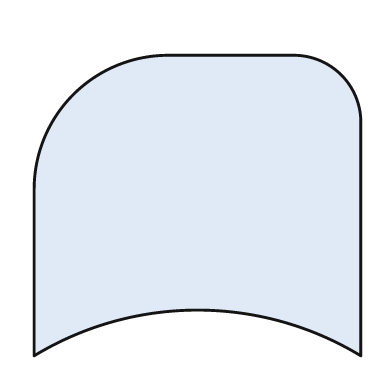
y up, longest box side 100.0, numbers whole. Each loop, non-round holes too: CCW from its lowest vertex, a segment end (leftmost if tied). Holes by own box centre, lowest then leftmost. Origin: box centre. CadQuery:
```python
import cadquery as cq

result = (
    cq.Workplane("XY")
    .moveTo(-50.0, -46.0)
    .threePointArc((0.0, -32.0), (50.0, -46.0))
    .lineTo(50.0, 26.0)
    .threePointArc((44.0, 40.0), (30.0, 46.0))
    .lineTo(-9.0, 46.0)
    .threePointArc((-38.0, 34.0), (-50.0, 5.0))
    .close()
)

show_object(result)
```